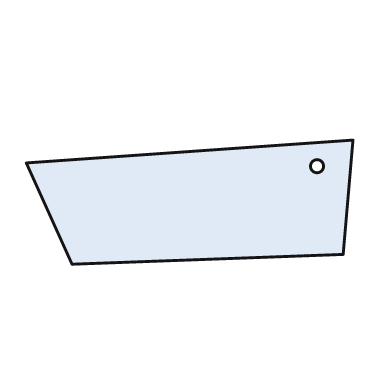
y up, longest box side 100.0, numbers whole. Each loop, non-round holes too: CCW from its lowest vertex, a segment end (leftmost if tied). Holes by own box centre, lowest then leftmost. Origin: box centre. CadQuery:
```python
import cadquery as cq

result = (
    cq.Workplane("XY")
    .moveTo(-36.0, -19.0)
    .lineTo(47.0, -16.0)
    .lineTo(50.0, 19.0)
    .lineTo(-50.0, 12.0)
    .close()
    .moveTo(39.0, 11.0)
    .circle(2.0)
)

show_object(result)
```